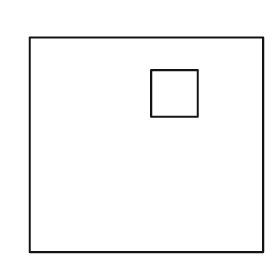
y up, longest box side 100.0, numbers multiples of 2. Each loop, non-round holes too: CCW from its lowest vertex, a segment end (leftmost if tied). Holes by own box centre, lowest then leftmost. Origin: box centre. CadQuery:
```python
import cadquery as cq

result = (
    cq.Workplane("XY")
    .moveTo(-50.0, -46.0)
    .lineTo(50.0, -46.0)
    .lineTo(50.0, 46.0)
    .lineTo(-50.0, 46.0)
    .close()
    .moveTo(2.0, 12.0)
    .lineTo(22.0, 12.0)
    .lineTo(22.0, 32.0)
    .lineTo(2.0, 32.0)
    .close()
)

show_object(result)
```